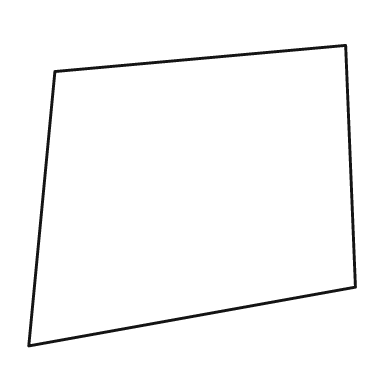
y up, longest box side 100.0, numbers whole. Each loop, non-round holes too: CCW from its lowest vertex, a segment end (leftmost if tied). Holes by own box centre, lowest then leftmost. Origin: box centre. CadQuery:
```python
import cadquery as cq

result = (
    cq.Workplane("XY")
    .moveTo(-50.0, -46.0)
    .lineTo(50.0, -28.0)
    .lineTo(47.0, 46.0)
    .lineTo(-42.0, 38.0)
    .close()
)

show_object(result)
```